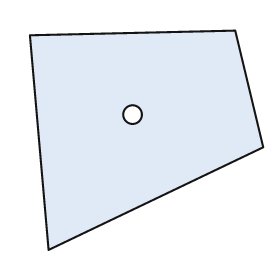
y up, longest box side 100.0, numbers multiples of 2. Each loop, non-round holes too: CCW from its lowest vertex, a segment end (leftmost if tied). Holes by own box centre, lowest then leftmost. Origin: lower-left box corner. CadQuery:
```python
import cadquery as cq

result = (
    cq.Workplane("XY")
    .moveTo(8.0, 0.0)
    .lineTo(100.0, 44.0)
    .lineTo(88.0, 94.0)
    .lineTo(0.0, 92.0)
    .close()
    .moveTo(44.0, 58.0)
    .circle(4.0)
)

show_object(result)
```